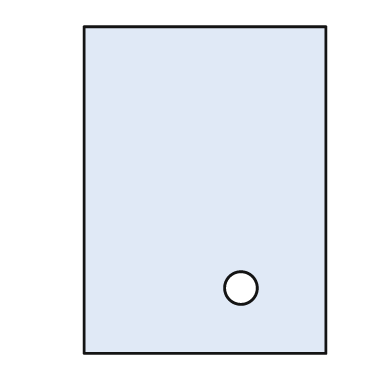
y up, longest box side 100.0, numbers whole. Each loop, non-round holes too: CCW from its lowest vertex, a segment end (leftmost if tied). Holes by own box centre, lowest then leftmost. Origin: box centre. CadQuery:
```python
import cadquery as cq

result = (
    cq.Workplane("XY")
    .moveTo(-37.0, -50.0)
    .lineTo(37.0, -50.0)
    .lineTo(37.0, 50.0)
    .lineTo(-37.0, 50.0)
    .close()
    .moveTo(11.0, -30.0)
    .circle(5.0)
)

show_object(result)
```